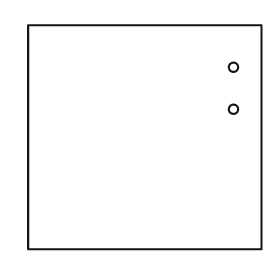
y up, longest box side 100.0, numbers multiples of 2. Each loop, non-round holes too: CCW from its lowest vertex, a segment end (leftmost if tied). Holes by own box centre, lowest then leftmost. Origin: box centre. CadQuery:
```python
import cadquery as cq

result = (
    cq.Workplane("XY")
    .moveTo(-50.0, -48.0)
    .lineTo(50.0, -48.0)
    .lineTo(50.0, 48.0)
    .lineTo(-50.0, 48.0)
    .close()
    .moveTo(38.0, 12.0)
    .circle(2.0)
    .moveTo(38.0, 30.0)
    .circle(2.0)
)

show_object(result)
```